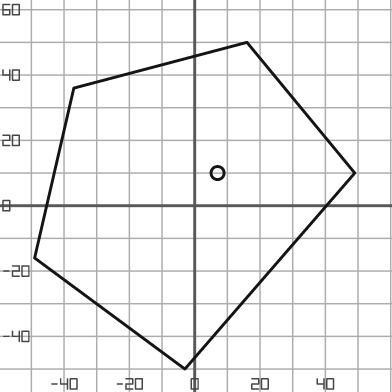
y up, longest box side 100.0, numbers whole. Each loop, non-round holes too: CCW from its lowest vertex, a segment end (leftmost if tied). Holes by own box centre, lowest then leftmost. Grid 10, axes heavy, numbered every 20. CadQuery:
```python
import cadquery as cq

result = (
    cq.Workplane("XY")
    .moveTo(-3.0, -50.0)
    .lineTo(49.0, 10.0)
    .lineTo(16.0, 50.0)
    .lineTo(-37.0, 36.0)
    .lineTo(-49.0, -16.0)
    .close()
    .moveTo(7.0, 10.0)
    .circle(2.0)
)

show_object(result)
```